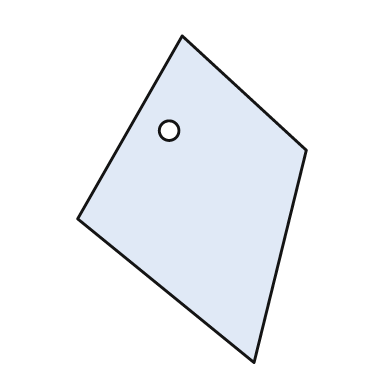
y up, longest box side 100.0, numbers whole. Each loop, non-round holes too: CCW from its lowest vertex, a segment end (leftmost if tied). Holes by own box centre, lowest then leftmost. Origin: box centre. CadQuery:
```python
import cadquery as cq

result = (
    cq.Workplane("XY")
    .moveTo(19.0, -50.0)
    .lineTo(35.0, 15.0)
    .lineTo(-3.0, 50.0)
    .lineTo(-35.0, -6.0)
    .close()
    .moveTo(-7.0, 21.0)
    .circle(3.0)
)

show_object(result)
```